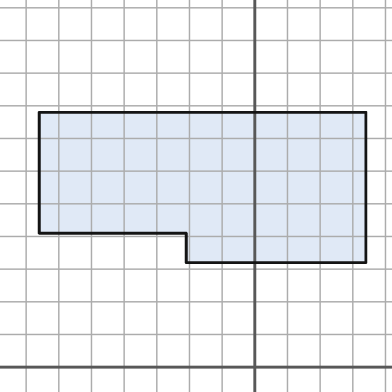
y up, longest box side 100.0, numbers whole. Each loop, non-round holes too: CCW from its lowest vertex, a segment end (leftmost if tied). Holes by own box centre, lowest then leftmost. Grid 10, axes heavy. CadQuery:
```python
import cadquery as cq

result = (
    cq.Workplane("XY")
    .moveTo(-21.0, 32.0)
    .lineTo(34.0, 32.0)
    .lineTo(34.0, 78.0)
    .lineTo(-66.0, 78.0)
    .lineTo(-66.0, 41.0)
    .lineTo(-21.0, 41.0)
    .close()
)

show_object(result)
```